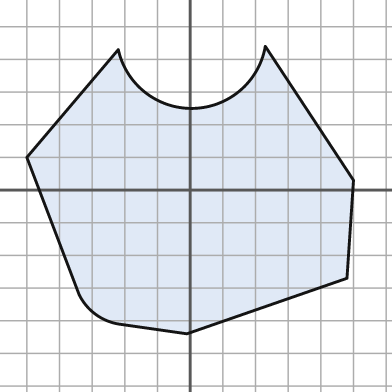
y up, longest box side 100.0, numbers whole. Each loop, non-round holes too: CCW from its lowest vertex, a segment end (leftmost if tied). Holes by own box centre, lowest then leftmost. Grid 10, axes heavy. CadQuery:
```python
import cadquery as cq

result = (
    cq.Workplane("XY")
    .moveTo(-1.0, -44.0)
    .lineTo(48.0, -27.0)
    .lineTo(50.0, 3.0)
    .lineTo(23.0, 44.0)
    .threePointArc((1.0, 25.0), (-22.0, 43.0))
    .lineTo(-50.0, 10.0)
    .lineTo(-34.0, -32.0)
    .threePointArc((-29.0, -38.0), (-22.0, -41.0))
    .close()
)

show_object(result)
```